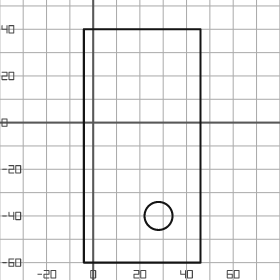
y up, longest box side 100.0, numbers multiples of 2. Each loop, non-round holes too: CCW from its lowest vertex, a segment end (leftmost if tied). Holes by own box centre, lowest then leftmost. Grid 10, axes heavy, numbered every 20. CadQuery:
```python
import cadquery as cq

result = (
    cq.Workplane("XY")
    .moveTo(-4.0, -60.0)
    .lineTo(46.0, -60.0)
    .lineTo(46.0, 40.0)
    .lineTo(-4.0, 40.0)
    .close()
    .moveTo(28.0, -40.0)
    .circle(6.0)
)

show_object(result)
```